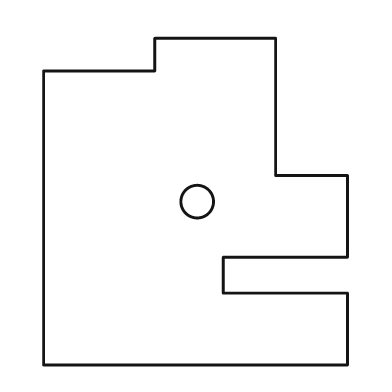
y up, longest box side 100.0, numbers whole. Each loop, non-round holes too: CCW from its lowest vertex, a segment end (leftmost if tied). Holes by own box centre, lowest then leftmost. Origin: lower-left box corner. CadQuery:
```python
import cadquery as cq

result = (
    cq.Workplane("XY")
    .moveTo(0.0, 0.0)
    .lineTo(93.0, 0.0)
    .lineTo(93.0, 22.0)
    .lineTo(55.0, 22.0)
    .lineTo(55.0, 33.0)
    .lineTo(93.0, 33.0)
    .lineTo(93.0, 58.0)
    .lineTo(71.0, 58.0)
    .lineTo(71.0, 100.0)
    .lineTo(34.0, 100.0)
    .lineTo(34.0, 90.0)
    .lineTo(0.0, 90.0)
    .close()
    .moveTo(47.0, 50.0)
    .circle(5.0)
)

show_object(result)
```